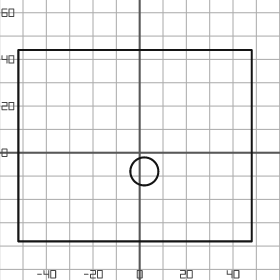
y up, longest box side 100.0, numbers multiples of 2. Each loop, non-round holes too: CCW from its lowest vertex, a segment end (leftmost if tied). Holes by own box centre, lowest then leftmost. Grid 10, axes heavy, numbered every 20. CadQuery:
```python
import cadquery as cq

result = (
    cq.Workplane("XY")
    .moveTo(-52.0, -38.0)
    .lineTo(48.0, -38.0)
    .lineTo(48.0, 44.0)
    .lineTo(-52.0, 44.0)
    .close()
    .moveTo(2.0, -8.0)
    .circle(6.0)
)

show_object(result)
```